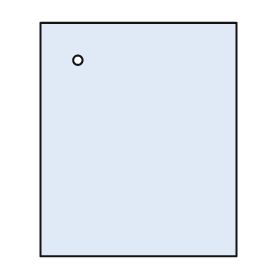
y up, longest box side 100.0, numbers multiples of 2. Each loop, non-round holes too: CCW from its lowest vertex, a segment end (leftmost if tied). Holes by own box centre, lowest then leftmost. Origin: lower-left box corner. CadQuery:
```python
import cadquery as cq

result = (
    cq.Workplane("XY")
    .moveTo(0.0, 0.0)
    .lineTo(84.0, 0.0)
    .lineTo(84.0, 100.0)
    .lineTo(0.0, 100.0)
    .close()
    .moveTo(16.0, 84.0)
    .circle(2.0)
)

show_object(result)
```